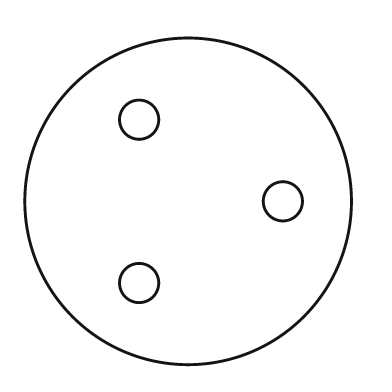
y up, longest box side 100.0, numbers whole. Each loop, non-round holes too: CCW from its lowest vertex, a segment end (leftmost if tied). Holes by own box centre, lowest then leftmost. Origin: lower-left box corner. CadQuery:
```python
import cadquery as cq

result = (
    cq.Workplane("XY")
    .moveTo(50.0, 50.0)
    .circle(50.0)
    .moveTo(35.0, 25.0)
    .circle(6.0)
    .moveTo(79.0, 50.0)
    .circle(6.0)
    .moveTo(35.0, 75.0)
    .circle(6.0)
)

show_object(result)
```